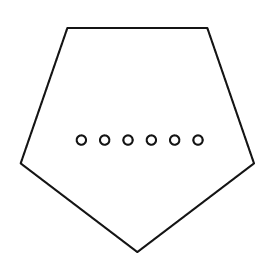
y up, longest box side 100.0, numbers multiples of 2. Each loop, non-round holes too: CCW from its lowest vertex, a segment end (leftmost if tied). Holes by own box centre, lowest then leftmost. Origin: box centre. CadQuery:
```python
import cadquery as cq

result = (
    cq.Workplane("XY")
    .moveTo(0.0, -48.0)
    .lineTo(50.0, -10.0)
    .lineTo(30.0, 48.0)
    .lineTo(-30.0, 48.0)
    .lineTo(-50.0, -10.0)
    .close()
    .moveTo(-24.0, 0.0)
    .circle(2.0)
    .moveTo(-14.0, 0.0)
    .circle(2.0)
    .moveTo(-4.0, 0.0)
    .circle(2.0)
    .moveTo(6.0, 0.0)
    .circle(2.0)
    .moveTo(16.0, 0.0)
    .circle(2.0)
    .moveTo(26.0, 0.0)
    .circle(2.0)
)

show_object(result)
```